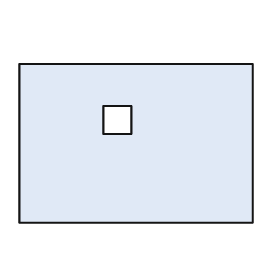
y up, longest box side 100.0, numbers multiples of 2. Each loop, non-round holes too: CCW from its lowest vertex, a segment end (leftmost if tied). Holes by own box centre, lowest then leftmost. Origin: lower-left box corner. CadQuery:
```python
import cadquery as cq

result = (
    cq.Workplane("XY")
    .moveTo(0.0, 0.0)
    .lineTo(100.0, 0.0)
    .lineTo(100.0, 68.0)
    .lineTo(0.0, 68.0)
    .close()
    .moveTo(36.0, 38.0)
    .lineTo(48.0, 38.0)
    .lineTo(48.0, 50.0)
    .lineTo(36.0, 50.0)
    .close()
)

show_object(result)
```